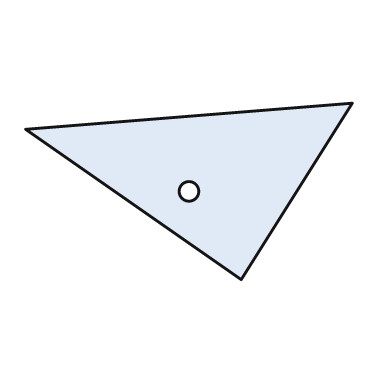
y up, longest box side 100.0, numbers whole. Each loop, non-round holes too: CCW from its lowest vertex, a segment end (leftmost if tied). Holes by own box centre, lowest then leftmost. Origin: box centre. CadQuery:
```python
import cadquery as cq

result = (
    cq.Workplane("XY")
    .moveTo(16.0, -27.0)
    .lineTo(50.0, 27.0)
    .lineTo(-50.0, 19.0)
    .close()
    .moveTo(0.0, 0.0)
    .circle(3.0)
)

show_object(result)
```